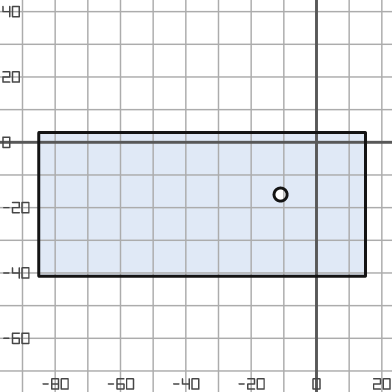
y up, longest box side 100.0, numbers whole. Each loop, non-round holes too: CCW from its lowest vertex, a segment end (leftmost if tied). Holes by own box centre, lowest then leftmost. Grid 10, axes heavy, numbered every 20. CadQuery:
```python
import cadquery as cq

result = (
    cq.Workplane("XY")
    .moveTo(-85.0, -41.0)
    .lineTo(15.0, -41.0)
    .lineTo(15.0, 3.0)
    .lineTo(-85.0, 3.0)
    .close()
    .moveTo(-11.0, -16.0)
    .circle(2.0)
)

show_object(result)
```